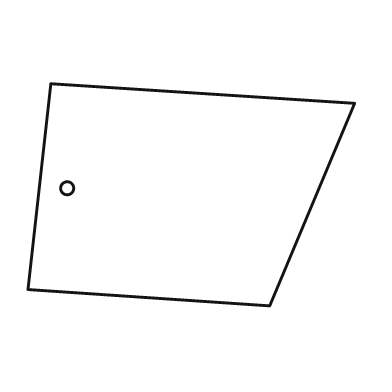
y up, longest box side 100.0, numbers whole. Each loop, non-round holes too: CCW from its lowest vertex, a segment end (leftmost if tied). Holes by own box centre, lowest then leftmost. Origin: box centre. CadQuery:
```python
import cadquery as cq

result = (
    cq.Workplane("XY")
    .moveTo(24.0, -34.0)
    .lineTo(50.0, 28.0)
    .lineTo(-43.0, 34.0)
    .lineTo(-50.0, -29.0)
    .close()
    .moveTo(-38.0, 2.0)
    .circle(2.0)
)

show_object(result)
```